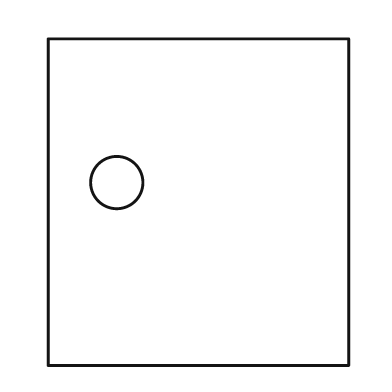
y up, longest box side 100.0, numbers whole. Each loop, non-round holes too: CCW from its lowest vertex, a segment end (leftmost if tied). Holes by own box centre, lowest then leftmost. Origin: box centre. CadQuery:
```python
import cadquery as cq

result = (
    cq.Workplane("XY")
    .moveTo(-46.0, -50.0)
    .lineTo(46.0, -50.0)
    .lineTo(46.0, 50.0)
    .lineTo(-46.0, 50.0)
    .close()
    .moveTo(-25.0, 6.0)
    .circle(8.0)
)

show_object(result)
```